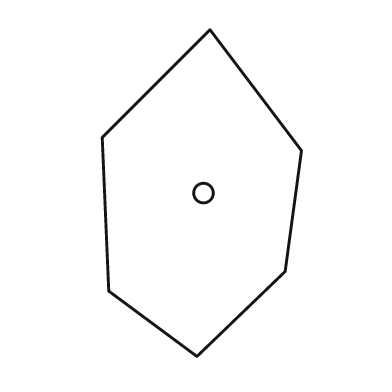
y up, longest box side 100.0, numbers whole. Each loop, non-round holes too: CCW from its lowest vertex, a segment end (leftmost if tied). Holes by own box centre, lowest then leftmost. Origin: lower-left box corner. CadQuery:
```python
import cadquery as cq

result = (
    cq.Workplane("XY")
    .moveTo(29.0, 0.0)
    .lineTo(56.0, 26.0)
    .lineTo(61.0, 63.0)
    .lineTo(33.0, 100.0)
    .lineTo(0.0, 67.0)
    .lineTo(2.0, 20.0)
    .close()
    .moveTo(31.0, 50.0)
    .circle(3.0)
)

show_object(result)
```